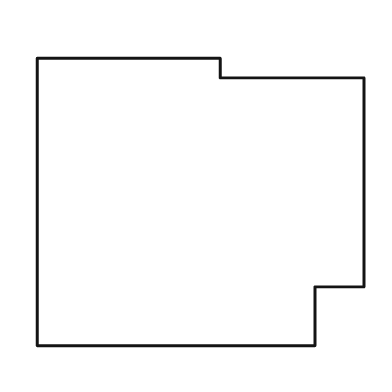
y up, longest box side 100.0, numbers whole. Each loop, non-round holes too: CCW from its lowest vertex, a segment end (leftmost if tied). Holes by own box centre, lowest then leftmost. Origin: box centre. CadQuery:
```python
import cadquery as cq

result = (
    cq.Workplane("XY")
    .moveTo(-50.0, -44.0)
    .lineTo(35.0, -44.0)
    .lineTo(35.0, -26.0)
    .lineTo(50.0, -26.0)
    .lineTo(50.0, 38.0)
    .lineTo(6.0, 38.0)
    .lineTo(6.0, 44.0)
    .lineTo(-50.0, 44.0)
    .close()
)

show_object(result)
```